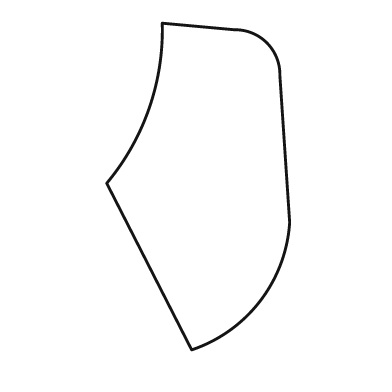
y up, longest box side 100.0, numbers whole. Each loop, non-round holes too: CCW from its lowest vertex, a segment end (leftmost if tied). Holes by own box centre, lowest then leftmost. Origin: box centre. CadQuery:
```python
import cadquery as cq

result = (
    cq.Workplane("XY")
    .moveTo(-2.0, -50.0)
    .threePointArc((19.0, -35.0), (28.0, -11.0))
    .lineTo(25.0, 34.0)
    .threePointArc((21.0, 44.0), (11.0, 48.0))
    .lineTo(-11.0, 50.0)
    .threePointArc((-15.0, 24.0), (-28.0, 1.0))
    .close()
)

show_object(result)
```